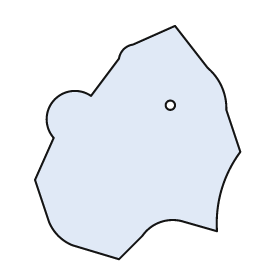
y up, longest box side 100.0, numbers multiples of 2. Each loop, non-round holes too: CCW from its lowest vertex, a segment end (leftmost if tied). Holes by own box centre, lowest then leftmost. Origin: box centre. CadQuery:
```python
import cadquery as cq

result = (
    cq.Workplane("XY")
    .moveTo(-8.0, -50.0)
    .lineTo(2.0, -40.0)
    .threePointArc((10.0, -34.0), (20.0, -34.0))
    .lineTo(34.0, -38.0)
    .threePointArc((36.0, -20.0), (44.0, -4.0))
    .lineTo(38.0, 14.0)
    .threePointArc((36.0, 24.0), (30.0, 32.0))
    .lineTo(16.0, 50.0)
    .lineTo(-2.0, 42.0)
    .threePointArc((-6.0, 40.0), (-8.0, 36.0))
    .lineTo(-20.0, 20.0)
    .threePointArc((-36.0, 18.0), (-36.0, 2.0))
    .lineTo(-44.0, -16.0)
    .lineTo(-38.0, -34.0)
    .threePointArc((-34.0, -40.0), (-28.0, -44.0))
    .close()
    .moveTo(14.0, 16.0)
    .circle(2.0)
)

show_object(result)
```